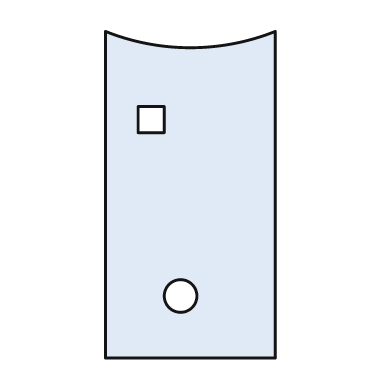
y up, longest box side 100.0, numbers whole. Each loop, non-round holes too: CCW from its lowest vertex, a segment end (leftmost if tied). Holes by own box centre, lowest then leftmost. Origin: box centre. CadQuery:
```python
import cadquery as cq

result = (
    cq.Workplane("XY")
    .moveTo(-26.0, -50.0)
    .lineTo(26.0, -50.0)
    .lineTo(26.0, 50.0)
    .threePointArc((0.0, 45.0), (-26.0, 50.0))
    .close()
    .moveTo(-3.0, -31.0)
    .circle(5.0)
    .moveTo(-16.0, 19.0)
    .lineTo(-8.0, 19.0)
    .lineTo(-8.0, 27.0)
    .lineTo(-16.0, 27.0)
    .close()
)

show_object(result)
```